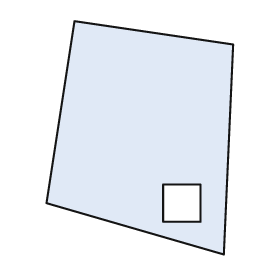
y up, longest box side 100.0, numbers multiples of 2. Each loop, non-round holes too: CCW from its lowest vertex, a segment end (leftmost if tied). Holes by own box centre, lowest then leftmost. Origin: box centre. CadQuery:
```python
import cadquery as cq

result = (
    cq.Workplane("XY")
    .moveTo(36.0, -50.0)
    .lineTo(40.0, 40.0)
    .lineTo(-28.0, 50.0)
    .lineTo(-40.0, -28.0)
    .close()
    .moveTo(10.0, -36.0)
    .lineTo(26.0, -36.0)
    .lineTo(26.0, -20.0)
    .lineTo(10.0, -20.0)
    .close()
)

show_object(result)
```